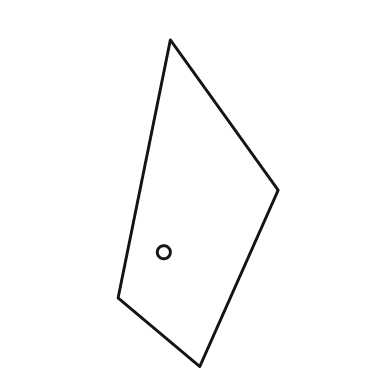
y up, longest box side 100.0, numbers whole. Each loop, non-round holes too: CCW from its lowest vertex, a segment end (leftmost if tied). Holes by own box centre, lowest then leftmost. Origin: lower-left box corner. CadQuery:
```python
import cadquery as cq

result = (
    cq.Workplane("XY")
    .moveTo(25.0, 0.0)
    .lineTo(49.0, 54.0)
    .lineTo(16.0, 100.0)
    .lineTo(0.0, 21.0)
    .close()
    .moveTo(14.0, 35.0)
    .circle(2.0)
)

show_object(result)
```